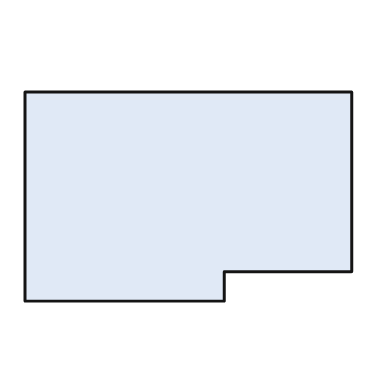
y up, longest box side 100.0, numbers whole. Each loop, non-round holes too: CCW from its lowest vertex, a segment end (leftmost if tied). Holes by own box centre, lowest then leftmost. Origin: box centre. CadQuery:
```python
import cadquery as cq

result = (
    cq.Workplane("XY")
    .moveTo(-50.0, -32.0)
    .lineTo(11.0, -32.0)
    .lineTo(11.0, -23.0)
    .lineTo(50.0, -23.0)
    .lineTo(50.0, 32.0)
    .lineTo(-50.0, 32.0)
    .close()
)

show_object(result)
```